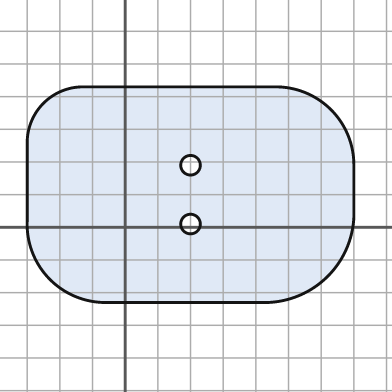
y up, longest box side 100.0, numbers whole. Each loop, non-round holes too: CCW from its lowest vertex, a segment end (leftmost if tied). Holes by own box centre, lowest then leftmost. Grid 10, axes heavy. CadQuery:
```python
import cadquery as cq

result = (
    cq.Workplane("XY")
    .moveTo(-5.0, -23.0)
    .lineTo(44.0, -23.0)
    .threePointArc((62.0, -15.0), (70.0, 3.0))
    .lineTo(70.0, 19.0)
    .threePointArc((63.0, 36.0), (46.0, 43.0))
    .lineTo(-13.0, 43.0)
    .threePointArc((-25.0, 38.0), (-30.0, 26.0))
    .lineTo(-30.0, 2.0)
    .threePointArc((-23.0, -16.0), (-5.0, -23.0))
    .close()
    .moveTo(20.0, 1.0)
    .circle(3.0)
    .moveTo(20.0, 19.0)
    .circle(3.0)
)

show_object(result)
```